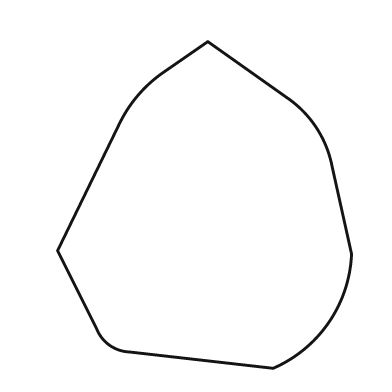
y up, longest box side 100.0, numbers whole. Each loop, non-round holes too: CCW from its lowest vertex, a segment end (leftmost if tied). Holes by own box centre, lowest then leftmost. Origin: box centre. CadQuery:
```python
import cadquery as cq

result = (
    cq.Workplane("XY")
    .moveTo(21.0, -50.0)
    .threePointArc((38.0, -36.0), (45.0, -15.0))
    .lineTo(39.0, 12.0)
    .threePointArc((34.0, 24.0), (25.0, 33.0))
    .lineTo(1.0, 50.0)
    .lineTo(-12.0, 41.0)
    .threePointArc((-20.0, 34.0), (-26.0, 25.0))
    .lineTo(-45.0, -14.0)
    .lineTo(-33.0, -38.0)
    .threePointArc((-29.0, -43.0), (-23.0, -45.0))
    .close()
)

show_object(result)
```